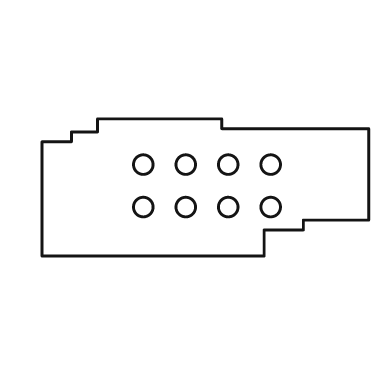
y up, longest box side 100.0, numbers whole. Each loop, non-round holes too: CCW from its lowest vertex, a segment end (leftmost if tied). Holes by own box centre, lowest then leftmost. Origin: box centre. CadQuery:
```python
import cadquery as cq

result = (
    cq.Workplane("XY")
    .moveTo(-50.0, -21.0)
    .lineTo(18.0, -21.0)
    .lineTo(18.0, -13.0)
    .lineTo(30.0, -13.0)
    .lineTo(30.0, -10.0)
    .lineTo(50.0, -10.0)
    .lineTo(50.0, 18.0)
    .lineTo(5.0, 18.0)
    .lineTo(5.0, 21.0)
    .lineTo(-33.0, 21.0)
    .lineTo(-33.0, 17.0)
    .lineTo(-41.0, 17.0)
    .lineTo(-41.0, 14.0)
    .lineTo(-50.0, 14.0)
    .close()
    .moveTo(-19.0, -6.0)
    .circle(3.0)
    .moveTo(-6.0, -6.0)
    .circle(3.0)
    .moveTo(7.0, -6.0)
    .circle(3.0)
    .moveTo(20.0, -6.0)
    .circle(3.0)
    .moveTo(-19.0, 7.0)
    .circle(3.0)
    .moveTo(-6.0, 7.0)
    .circle(3.0)
    .moveTo(7.0, 7.0)
    .circle(3.0)
    .moveTo(20.0, 7.0)
    .circle(3.0)
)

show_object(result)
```